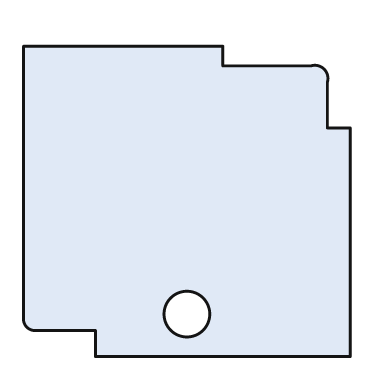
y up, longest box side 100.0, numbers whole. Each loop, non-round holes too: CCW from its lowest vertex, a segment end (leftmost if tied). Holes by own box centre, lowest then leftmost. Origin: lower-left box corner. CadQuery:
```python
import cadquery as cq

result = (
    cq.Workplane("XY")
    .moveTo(22.0, 0.0)
    .lineTo(100.0, 0.0)
    .lineTo(100.0, 70.0)
    .lineTo(93.0, 70.0)
    .lineTo(93.0, 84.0)
    .threePointArc((92.0, 88.0), (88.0, 89.0))
    .lineTo(61.0, 89.0)
    .lineTo(61.0, 95.0)
    .lineTo(0.0, 95.0)
    .lineTo(0.0, 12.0)
    .threePointArc((1.0, 9.0), (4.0, 8.0))
    .lineTo(22.0, 8.0)
    .close()
    .moveTo(50.0, 13.0)
    .circle(7.0)
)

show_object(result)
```